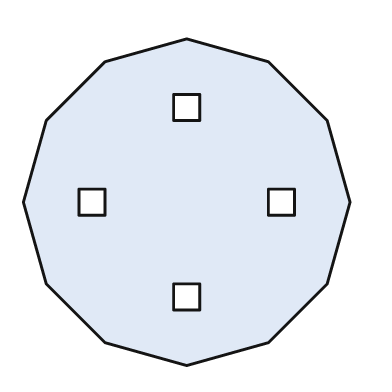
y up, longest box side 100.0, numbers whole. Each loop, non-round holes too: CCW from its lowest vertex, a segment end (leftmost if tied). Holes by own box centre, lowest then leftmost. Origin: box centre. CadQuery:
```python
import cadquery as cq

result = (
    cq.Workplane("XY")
    .moveTo(0.0, -50.0)
    .lineTo(25.0, -43.0)
    .lineTo(43.0, -25.0)
    .lineTo(50.0, 0.0)
    .lineTo(43.0, 25.0)
    .lineTo(25.0, 43.0)
    .lineTo(0.0, 50.0)
    .lineTo(-25.0, 43.0)
    .lineTo(-43.0, 25.0)
    .lineTo(-50.0, 0.0)
    .lineTo(-43.0, -25.0)
    .lineTo(-25.0, -43.0)
    .close()
    .moveTo(-4.0, -33.0)
    .lineTo(4.0, -33.0)
    .lineTo(4.0, -25.0)
    .lineTo(-4.0, -25.0)
    .close()
    .moveTo(-33.0, -4.0)
    .lineTo(-25.0, -4.0)
    .lineTo(-25.0, 4.0)
    .lineTo(-33.0, 4.0)
    .close()
    .moveTo(25.0, -4.0)
    .lineTo(33.0, -4.0)
    .lineTo(33.0, 4.0)
    .lineTo(25.0, 4.0)
    .close()
    .moveTo(-4.0, 25.0)
    .lineTo(4.0, 25.0)
    .lineTo(4.0, 33.0)
    .lineTo(-4.0, 33.0)
    .close()
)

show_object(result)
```